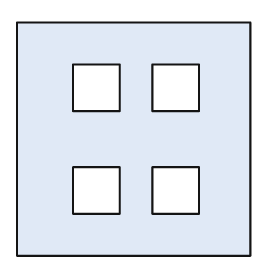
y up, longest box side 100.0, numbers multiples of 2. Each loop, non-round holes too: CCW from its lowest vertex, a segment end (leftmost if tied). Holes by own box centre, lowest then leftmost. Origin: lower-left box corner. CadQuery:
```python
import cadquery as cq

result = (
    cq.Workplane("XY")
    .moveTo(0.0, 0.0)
    .lineTo(100.0, 0.0)
    .lineTo(100.0, 100.0)
    .lineTo(0.0, 100.0)
    .close()
    .moveTo(24.0, 18.0)
    .lineTo(44.0, 18.0)
    .lineTo(44.0, 38.0)
    .lineTo(24.0, 38.0)
    .close()
    .moveTo(58.0, 18.0)
    .lineTo(78.0, 18.0)
    .lineTo(78.0, 38.0)
    .lineTo(58.0, 38.0)
    .close()
    .moveTo(24.0, 62.0)
    .lineTo(44.0, 62.0)
    .lineTo(44.0, 82.0)
    .lineTo(24.0, 82.0)
    .close()
    .moveTo(58.0, 62.0)
    .lineTo(78.0, 62.0)
    .lineTo(78.0, 82.0)
    .lineTo(58.0, 82.0)
    .close()
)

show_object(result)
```